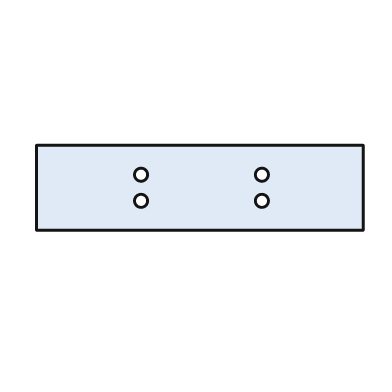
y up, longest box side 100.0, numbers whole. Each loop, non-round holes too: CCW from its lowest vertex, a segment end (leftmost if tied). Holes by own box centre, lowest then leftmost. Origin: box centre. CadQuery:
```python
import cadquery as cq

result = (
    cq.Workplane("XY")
    .moveTo(-50.0, -13.0)
    .lineTo(50.0, -13.0)
    .lineTo(50.0, 13.0)
    .lineTo(-50.0, 13.0)
    .close()
    .moveTo(-18.0, -4.0)
    .circle(2.0)
    .moveTo(19.0, -4.0)
    .circle(2.0)
    .moveTo(-18.0, 4.0)
    .circle(2.0)
    .moveTo(19.0, 4.0)
    .circle(2.0)
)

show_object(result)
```